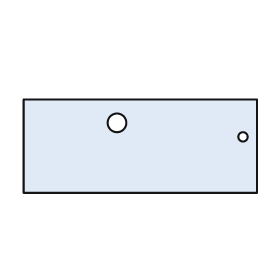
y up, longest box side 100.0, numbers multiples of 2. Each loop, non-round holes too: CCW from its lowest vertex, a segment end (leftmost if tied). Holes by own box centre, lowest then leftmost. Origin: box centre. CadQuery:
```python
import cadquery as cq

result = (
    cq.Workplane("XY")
    .moveTo(-50.0, -20.0)
    .lineTo(50.0, -20.0)
    .lineTo(50.0, 20.0)
    .lineTo(-50.0, 20.0)
    .close()
    .moveTo(44.0, 4.0)
    .circle(2.0)
    .moveTo(-10.0, 10.0)
    .circle(4.0)
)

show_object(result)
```